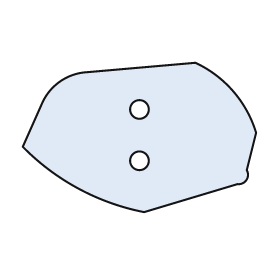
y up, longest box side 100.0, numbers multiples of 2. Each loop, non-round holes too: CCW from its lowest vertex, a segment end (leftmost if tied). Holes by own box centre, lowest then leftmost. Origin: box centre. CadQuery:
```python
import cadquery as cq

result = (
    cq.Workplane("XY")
    .moveTo(2.0, -32.0)
    .lineTo(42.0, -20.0)
    .threePointArc((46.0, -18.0), (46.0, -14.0))
    .lineTo(50.0, 2.0)
    .threePointArc((40.0, 20.0), (24.0, 32.0))
    .lineTo(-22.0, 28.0)
    .threePointArc((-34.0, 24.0), (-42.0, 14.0))
    .lineTo(-50.0, -4.0)
    .threePointArc((-26.0, -22.0), (2.0, -32.0))
    .close()
    .moveTo(0.0, -10.0)
    .circle(4.0)
    .moveTo(0.0, 12.0)
    .circle(4.0)
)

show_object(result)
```